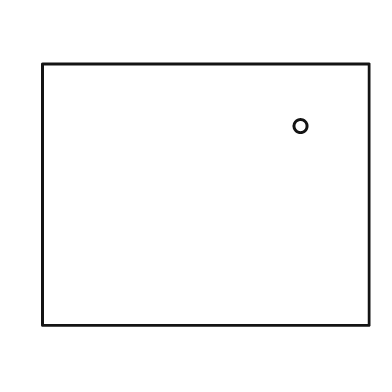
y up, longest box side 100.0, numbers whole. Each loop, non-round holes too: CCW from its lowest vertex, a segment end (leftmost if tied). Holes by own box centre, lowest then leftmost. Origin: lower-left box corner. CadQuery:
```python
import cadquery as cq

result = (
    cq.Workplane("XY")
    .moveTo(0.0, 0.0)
    .lineTo(100.0, 0.0)
    .lineTo(100.0, 80.0)
    .lineTo(0.0, 80.0)
    .close()
    .moveTo(79.0, 61.0)
    .circle(2.0)
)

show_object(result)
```